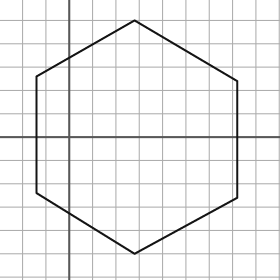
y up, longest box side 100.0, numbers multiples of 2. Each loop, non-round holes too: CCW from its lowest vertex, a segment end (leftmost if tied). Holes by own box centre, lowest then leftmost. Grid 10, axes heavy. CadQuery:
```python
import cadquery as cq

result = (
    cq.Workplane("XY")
    .moveTo(28.0, -50.0)
    .lineTo(72.0, -26.0)
    .lineTo(72.0, 24.0)
    .lineTo(28.0, 50.0)
    .lineTo(-14.0, 26.0)
    .lineTo(-14.0, -24.0)
    .close()
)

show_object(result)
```